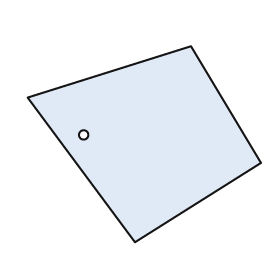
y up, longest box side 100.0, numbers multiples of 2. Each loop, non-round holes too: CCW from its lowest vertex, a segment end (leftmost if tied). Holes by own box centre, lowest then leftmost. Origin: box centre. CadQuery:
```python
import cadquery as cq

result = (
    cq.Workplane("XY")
    .moveTo(-4.0, -42.0)
    .lineTo(50.0, -8.0)
    .lineTo(20.0, 42.0)
    .lineTo(-50.0, 20.0)
    .close()
    .moveTo(-26.0, 4.0)
    .circle(2.0)
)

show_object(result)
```